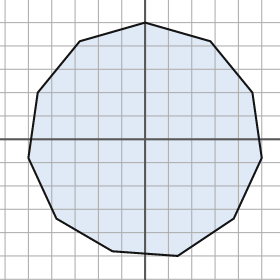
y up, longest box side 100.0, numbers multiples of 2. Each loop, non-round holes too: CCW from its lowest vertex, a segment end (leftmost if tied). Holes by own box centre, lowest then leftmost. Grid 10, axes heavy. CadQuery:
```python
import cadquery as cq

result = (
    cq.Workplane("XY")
    .moveTo(14.0, -50.0)
    .lineTo(38.0, -34.0)
    .lineTo(50.0, -8.0)
    .lineTo(46.0, 20.0)
    .lineTo(28.0, 42.0)
    .lineTo(0.0, 50.0)
    .lineTo(-28.0, 42.0)
    .lineTo(-46.0, 20.0)
    .lineTo(-50.0, -8.0)
    .lineTo(-38.0, -34.0)
    .lineTo(-14.0, -48.0)
    .close()
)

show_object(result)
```